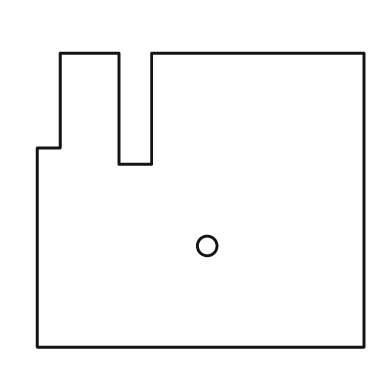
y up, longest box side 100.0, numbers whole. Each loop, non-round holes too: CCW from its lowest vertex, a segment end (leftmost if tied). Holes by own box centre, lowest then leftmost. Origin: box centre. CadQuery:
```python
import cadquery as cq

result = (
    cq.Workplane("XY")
    .moveTo(-50.0, -45.0)
    .lineTo(50.0, -45.0)
    .lineTo(50.0, 45.0)
    .lineTo(-15.0, 45.0)
    .lineTo(-15.0, 11.0)
    .lineTo(-25.0, 11.0)
    .lineTo(-25.0, 45.0)
    .lineTo(-43.0, 45.0)
    .lineTo(-43.0, 16.0)
    .lineTo(-50.0, 16.0)
    .close()
    .moveTo(2.0, -14.0)
    .circle(3.0)
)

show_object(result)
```